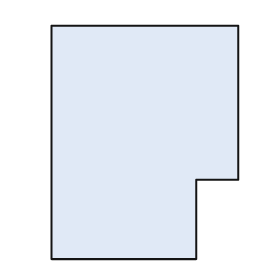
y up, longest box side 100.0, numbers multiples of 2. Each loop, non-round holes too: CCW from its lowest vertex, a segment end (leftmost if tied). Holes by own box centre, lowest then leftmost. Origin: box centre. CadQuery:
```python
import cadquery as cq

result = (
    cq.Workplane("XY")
    .moveTo(-40.0, -50.0)
    .lineTo(22.0, -50.0)
    .lineTo(22.0, -16.0)
    .lineTo(40.0, -16.0)
    .lineTo(40.0, 50.0)
    .lineTo(-40.0, 50.0)
    .close()
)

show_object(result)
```